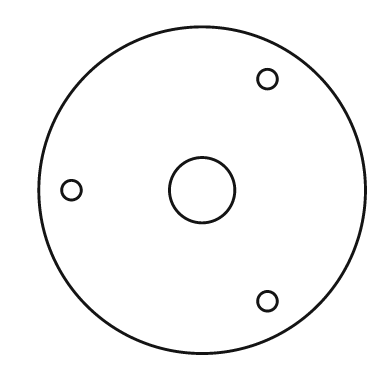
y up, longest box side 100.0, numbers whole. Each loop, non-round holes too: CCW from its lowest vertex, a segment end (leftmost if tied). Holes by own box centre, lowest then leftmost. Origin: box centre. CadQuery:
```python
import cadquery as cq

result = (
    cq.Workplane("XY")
    .moveTo(0.0, 0.0)
    .circle(50.0)
    .moveTo(20.0, -34.0)
    .circle(3.0)
    .moveTo(-40.0, 0.0)
    .circle(3.0)
    .moveTo(0.0, 0.0)
    .circle(10.0)
    .moveTo(20.0, 34.0)
    .circle(3.0)
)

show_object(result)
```